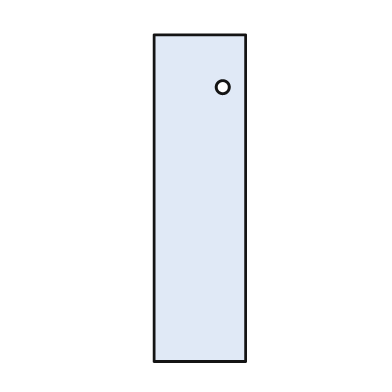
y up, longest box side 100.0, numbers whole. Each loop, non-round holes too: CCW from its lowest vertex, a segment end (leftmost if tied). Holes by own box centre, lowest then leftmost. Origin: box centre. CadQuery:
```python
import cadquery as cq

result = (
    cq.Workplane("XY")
    .moveTo(-14.0, -50.0)
    .lineTo(14.0, -50.0)
    .lineTo(14.0, 50.0)
    .lineTo(-14.0, 50.0)
    .close()
    .moveTo(7.0, 34.0)
    .circle(2.0)
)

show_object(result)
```